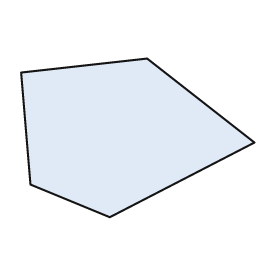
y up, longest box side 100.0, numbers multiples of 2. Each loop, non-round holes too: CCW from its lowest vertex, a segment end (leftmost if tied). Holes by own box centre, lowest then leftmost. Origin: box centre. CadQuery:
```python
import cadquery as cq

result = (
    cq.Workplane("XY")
    .moveTo(-12.0, -34.0)
    .lineTo(50.0, -2.0)
    .lineTo(4.0, 34.0)
    .lineTo(-50.0, 28.0)
    .lineTo(-46.0, -20.0)
    .close()
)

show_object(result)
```